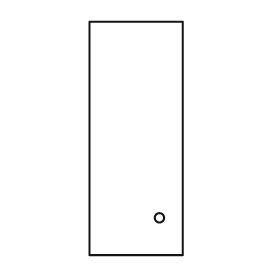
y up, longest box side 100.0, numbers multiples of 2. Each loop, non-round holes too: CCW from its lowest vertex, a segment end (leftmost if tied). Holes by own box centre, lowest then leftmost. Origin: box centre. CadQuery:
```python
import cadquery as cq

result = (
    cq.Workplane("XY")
    .moveTo(-20.0, -50.0)
    .lineTo(20.0, -50.0)
    .lineTo(20.0, 50.0)
    .lineTo(-20.0, 50.0)
    .close()
    .moveTo(10.0, -34.0)
    .circle(2.0)
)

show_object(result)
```